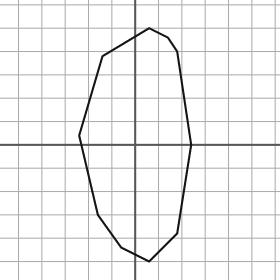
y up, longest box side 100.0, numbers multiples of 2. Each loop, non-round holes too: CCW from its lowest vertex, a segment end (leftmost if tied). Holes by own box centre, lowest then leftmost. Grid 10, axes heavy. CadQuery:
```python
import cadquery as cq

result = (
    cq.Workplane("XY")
    .moveTo(6.0, -50.0)
    .lineTo(18.0, -38.0)
    .lineTo(24.0, 0.0)
    .lineTo(18.0, 40.0)
    .lineTo(14.0, 46.0)
    .lineTo(6.0, 50.0)
    .lineTo(-14.0, 38.0)
    .lineTo(-24.0, 4.0)
    .lineTo(-16.0, -30.0)
    .lineTo(-6.0, -44.0)
    .close()
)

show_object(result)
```